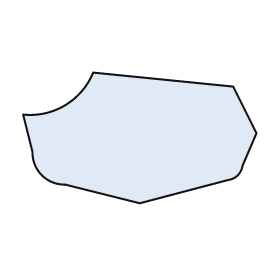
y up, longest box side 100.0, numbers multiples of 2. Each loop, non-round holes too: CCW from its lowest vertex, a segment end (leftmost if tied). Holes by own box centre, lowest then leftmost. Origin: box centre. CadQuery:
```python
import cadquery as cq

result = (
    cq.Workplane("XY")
    .moveTo(0.0, -28.0)
    .lineTo(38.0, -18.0)
    .threePointArc((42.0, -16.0), (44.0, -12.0))
    .lineTo(50.0, 2.0)
    .lineTo(40.0, 22.0)
    .lineTo(-20.0, 28.0)
    .threePointArc((-32.0, 14.0), (-50.0, 10.0))
    .lineTo(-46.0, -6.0)
    .threePointArc((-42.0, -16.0), (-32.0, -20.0))
    .close()
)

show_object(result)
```